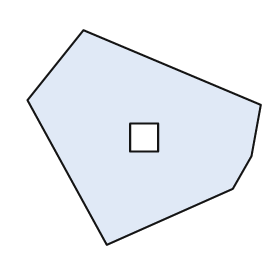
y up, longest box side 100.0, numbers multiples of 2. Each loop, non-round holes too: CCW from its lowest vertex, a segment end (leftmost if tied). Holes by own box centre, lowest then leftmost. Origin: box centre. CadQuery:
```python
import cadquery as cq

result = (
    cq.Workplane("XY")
    .moveTo(-16.0, -46.0)
    .lineTo(38.0, -22.0)
    .lineTo(46.0, -8.0)
    .lineTo(50.0, 14.0)
    .lineTo(-26.0, 46.0)
    .lineTo(-50.0, 16.0)
    .close()
    .moveTo(-6.0, -6.0)
    .lineTo(6.0, -6.0)
    .lineTo(6.0, 6.0)
    .lineTo(-6.0, 6.0)
    .close()
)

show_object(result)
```